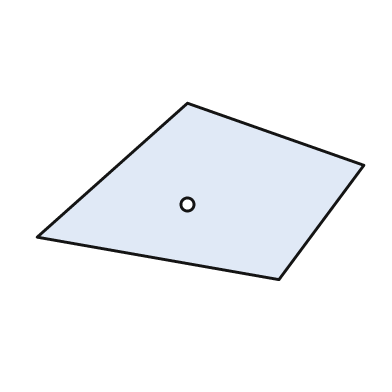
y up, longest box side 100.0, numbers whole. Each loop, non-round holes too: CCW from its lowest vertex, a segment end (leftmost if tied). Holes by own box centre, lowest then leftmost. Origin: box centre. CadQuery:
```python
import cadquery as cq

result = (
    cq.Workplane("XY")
    .moveTo(24.0, -27.0)
    .lineTo(50.0, 8.0)
    .lineTo(-4.0, 27.0)
    .lineTo(-50.0, -14.0)
    .close()
    .moveTo(-4.0, -4.0)
    .circle(2.0)
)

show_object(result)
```